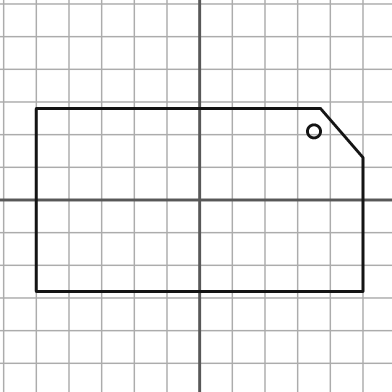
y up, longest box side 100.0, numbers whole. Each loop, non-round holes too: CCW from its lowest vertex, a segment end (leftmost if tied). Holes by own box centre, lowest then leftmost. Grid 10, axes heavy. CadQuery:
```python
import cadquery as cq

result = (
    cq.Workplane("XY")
    .moveTo(-50.0, -28.0)
    .lineTo(50.0, -28.0)
    .lineTo(50.0, 13.0)
    .lineTo(37.0, 28.0)
    .lineTo(-50.0, 28.0)
    .close()
    .moveTo(35.0, 21.0)
    .circle(2.0)
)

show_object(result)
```